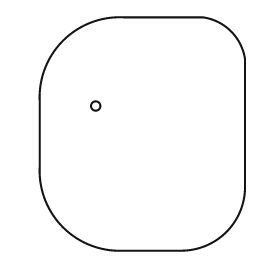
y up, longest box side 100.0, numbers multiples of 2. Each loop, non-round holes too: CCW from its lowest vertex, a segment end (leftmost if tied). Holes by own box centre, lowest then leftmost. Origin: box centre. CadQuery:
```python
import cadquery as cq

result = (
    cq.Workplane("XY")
    .moveTo(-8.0, -50.0)
    .lineTo(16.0, -50.0)
    .threePointArc((36.0, -42.0), (44.0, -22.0))
    .lineTo(44.0, 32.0)
    .threePointArc((38.0, 44.0), (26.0, 50.0))
    .lineTo(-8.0, 50.0)
    .threePointArc((-34.0, 40.0), (-44.0, 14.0))
    .lineTo(-44.0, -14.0)
    .threePointArc((-34.0, -40.0), (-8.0, -50.0))
    .close()
    .moveTo(-20.0, 12.0)
    .circle(2.0)
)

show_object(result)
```